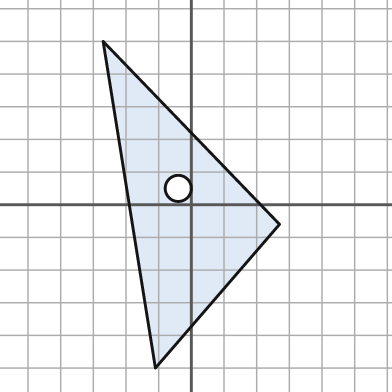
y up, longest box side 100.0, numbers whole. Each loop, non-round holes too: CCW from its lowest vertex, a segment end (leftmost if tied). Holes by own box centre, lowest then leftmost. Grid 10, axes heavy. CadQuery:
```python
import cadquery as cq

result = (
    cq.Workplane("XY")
    .moveTo(-11.0, -50.0)
    .lineTo(27.0, -6.0)
    .lineTo(-27.0, 50.0)
    .close()
    .moveTo(-4.0, 5.0)
    .circle(4.0)
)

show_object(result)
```